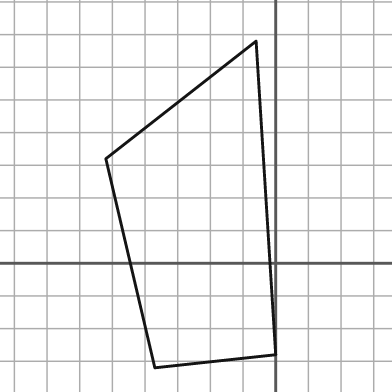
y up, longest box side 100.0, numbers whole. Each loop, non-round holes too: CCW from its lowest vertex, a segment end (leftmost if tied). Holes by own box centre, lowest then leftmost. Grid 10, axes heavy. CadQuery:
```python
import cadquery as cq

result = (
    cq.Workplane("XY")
    .moveTo(-37.0, -32.0)
    .lineTo(0.0, -28.0)
    .lineTo(-6.0, 68.0)
    .lineTo(-52.0, 32.0)
    .close()
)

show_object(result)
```